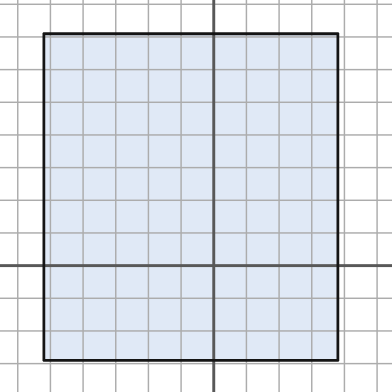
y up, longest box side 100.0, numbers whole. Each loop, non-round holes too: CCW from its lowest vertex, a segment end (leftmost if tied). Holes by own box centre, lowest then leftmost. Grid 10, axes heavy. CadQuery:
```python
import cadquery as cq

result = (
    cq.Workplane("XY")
    .moveTo(-52.0, -29.0)
    .lineTo(38.0, -29.0)
    .lineTo(38.0, 71.0)
    .lineTo(-52.0, 71.0)
    .close()
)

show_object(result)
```